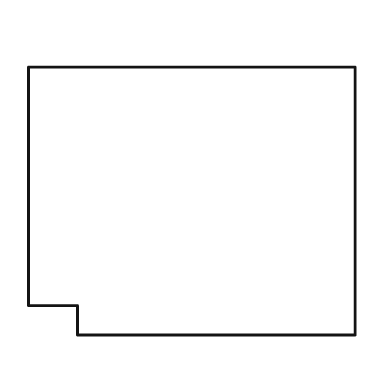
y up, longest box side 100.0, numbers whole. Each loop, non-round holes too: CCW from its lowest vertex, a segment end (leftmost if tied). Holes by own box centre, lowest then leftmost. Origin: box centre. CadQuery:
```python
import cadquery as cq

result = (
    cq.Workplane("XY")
    .moveTo(-35.0, -41.0)
    .lineTo(50.0, -41.0)
    .lineTo(50.0, 41.0)
    .lineTo(-50.0, 41.0)
    .lineTo(-50.0, -32.0)
    .lineTo(-35.0, -32.0)
    .close()
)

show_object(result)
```